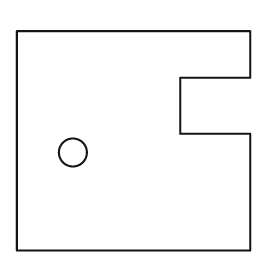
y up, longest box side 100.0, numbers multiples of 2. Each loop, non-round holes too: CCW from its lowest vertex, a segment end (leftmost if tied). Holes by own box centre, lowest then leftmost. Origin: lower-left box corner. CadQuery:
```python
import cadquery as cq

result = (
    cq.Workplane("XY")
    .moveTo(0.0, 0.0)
    .lineTo(100.0, 0.0)
    .lineTo(100.0, 50.0)
    .lineTo(70.0, 50.0)
    .lineTo(70.0, 74.0)
    .lineTo(100.0, 74.0)
    .lineTo(100.0, 94.0)
    .lineTo(0.0, 94.0)
    .close()
    .moveTo(24.0, 42.0)
    .circle(6.0)
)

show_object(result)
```